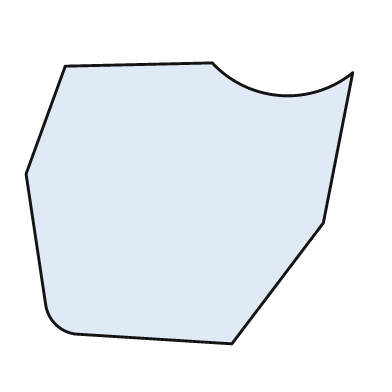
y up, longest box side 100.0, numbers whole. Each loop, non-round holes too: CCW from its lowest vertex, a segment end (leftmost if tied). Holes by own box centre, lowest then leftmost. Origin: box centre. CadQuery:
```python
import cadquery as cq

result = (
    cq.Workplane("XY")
    .moveTo(13.0, -43.0)
    .lineTo(41.0, -6.0)
    .lineTo(50.0, 40.0)
    .threePointArc((28.0, 33.0), (7.0, 43.0))
    .lineTo(-38.0, 42.0)
    .lineTo(-50.0, 9.0)
    .lineTo(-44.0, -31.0)
    .threePointArc((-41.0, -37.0), (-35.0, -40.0))
    .close()
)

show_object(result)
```